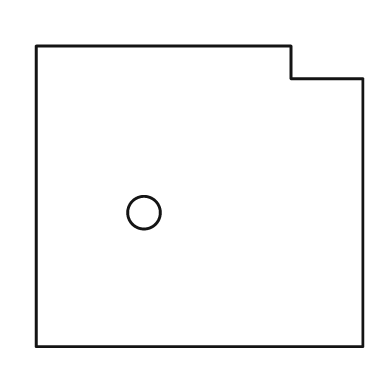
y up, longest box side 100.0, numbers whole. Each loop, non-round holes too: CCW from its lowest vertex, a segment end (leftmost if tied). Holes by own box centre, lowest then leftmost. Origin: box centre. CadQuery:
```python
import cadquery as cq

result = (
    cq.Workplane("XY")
    .moveTo(-50.0, -46.0)
    .lineTo(50.0, -46.0)
    .lineTo(50.0, 36.0)
    .lineTo(28.0, 36.0)
    .lineTo(28.0, 46.0)
    .lineTo(-50.0, 46.0)
    .close()
    .moveTo(-17.0, -5.0)
    .circle(5.0)
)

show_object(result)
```